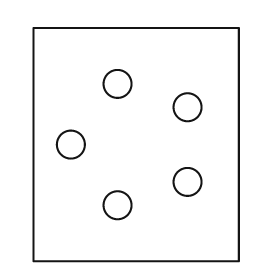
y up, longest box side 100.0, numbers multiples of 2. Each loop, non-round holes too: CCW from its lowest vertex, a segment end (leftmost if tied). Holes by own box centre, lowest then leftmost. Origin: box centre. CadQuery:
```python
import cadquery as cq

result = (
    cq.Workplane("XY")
    .moveTo(-44.0, -50.0)
    .lineTo(44.0, -50.0)
    .lineTo(44.0, 50.0)
    .lineTo(-44.0, 50.0)
    .close()
    .moveTo(-8.0, -26.0)
    .circle(6.0)
    .moveTo(22.0, -16.0)
    .circle(6.0)
    .moveTo(-28.0, 0.0)
    .circle(6.0)
    .moveTo(22.0, 16.0)
    .circle(6.0)
    .moveTo(-8.0, 26.0)
    .circle(6.0)
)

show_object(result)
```